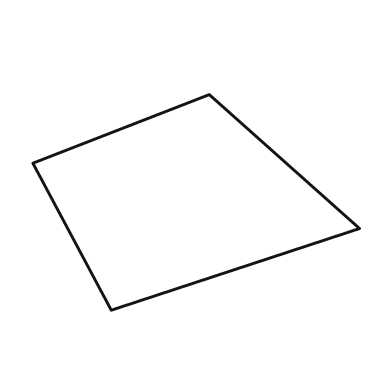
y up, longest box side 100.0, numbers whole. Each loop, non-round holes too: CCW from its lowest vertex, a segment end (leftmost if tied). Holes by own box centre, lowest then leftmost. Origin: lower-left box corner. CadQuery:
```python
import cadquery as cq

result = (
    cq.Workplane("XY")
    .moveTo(24.0, 0.0)
    .lineTo(100.0, 25.0)
    .lineTo(54.0, 66.0)
    .lineTo(0.0, 45.0)
    .close()
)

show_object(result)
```